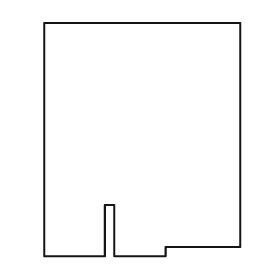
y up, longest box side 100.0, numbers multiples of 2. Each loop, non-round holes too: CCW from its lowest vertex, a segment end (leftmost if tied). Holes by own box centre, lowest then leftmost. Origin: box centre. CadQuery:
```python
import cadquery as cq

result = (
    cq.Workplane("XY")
    .moveTo(-42.0, -50.0)
    .lineTo(-16.0, -50.0)
    .lineTo(-16.0, -28.0)
    .lineTo(-12.0, -28.0)
    .lineTo(-12.0, -50.0)
    .lineTo(10.0, -50.0)
    .lineTo(10.0, -46.0)
    .lineTo(42.0, -46.0)
    .lineTo(42.0, 50.0)
    .lineTo(-42.0, 50.0)
    .close()
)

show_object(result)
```